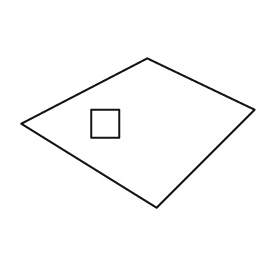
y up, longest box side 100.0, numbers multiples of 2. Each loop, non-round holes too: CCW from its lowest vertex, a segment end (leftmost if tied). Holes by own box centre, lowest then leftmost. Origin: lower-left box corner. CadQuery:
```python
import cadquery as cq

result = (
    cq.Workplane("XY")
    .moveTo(58.0, 0.0)
    .lineTo(100.0, 42.0)
    .lineTo(54.0, 64.0)
    .lineTo(0.0, 36.0)
    .close()
    .moveTo(30.0, 30.0)
    .lineTo(42.0, 30.0)
    .lineTo(42.0, 42.0)
    .lineTo(30.0, 42.0)
    .close()
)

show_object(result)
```